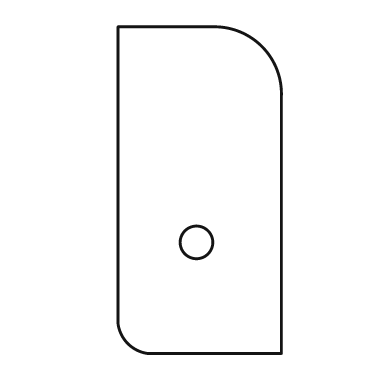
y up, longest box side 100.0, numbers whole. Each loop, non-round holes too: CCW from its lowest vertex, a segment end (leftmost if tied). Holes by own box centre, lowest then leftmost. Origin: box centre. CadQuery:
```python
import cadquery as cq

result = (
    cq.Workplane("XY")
    .moveTo(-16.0, -50.0)
    .lineTo(25.0, -50.0)
    .lineTo(25.0, 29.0)
    .threePointArc((19.0, 44.0), (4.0, 50.0))
    .lineTo(-25.0, 50.0)
    .lineTo(-25.0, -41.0)
    .threePointArc((-22.0, -47.0), (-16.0, -50.0))
    .close()
    .moveTo(-1.0, -16.0)
    .circle(5.0)
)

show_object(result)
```